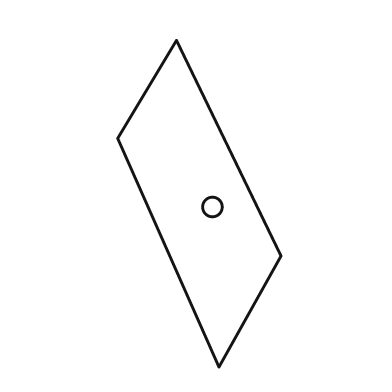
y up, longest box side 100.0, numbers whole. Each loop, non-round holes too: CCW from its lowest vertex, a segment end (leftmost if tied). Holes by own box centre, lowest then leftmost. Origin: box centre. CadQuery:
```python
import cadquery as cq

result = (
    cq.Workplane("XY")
    .moveTo(6.0, -50.0)
    .lineTo(25.0, -16.0)
    .lineTo(-7.0, 50.0)
    .lineTo(-25.0, 20.0)
    .close()
    .moveTo(4.0, -1.0)
    .circle(3.0)
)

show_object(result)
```